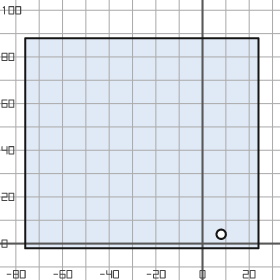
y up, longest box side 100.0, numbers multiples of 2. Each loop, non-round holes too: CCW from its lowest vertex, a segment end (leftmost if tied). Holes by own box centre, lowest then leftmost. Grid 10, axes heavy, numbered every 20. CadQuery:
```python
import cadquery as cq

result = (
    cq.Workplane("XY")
    .moveTo(-76.0, -2.0)
    .lineTo(24.0, -2.0)
    .lineTo(24.0, 88.0)
    .lineTo(-76.0, 88.0)
    .close()
    .moveTo(8.0, 4.0)
    .circle(2.0)
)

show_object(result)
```